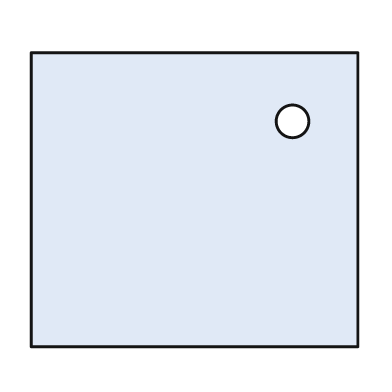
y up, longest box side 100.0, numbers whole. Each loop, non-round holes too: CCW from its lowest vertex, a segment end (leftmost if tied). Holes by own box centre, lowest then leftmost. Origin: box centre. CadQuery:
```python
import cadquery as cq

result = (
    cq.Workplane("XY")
    .moveTo(-50.0, -45.0)
    .lineTo(50.0, -45.0)
    .lineTo(50.0, 45.0)
    .lineTo(-50.0, 45.0)
    .close()
    .moveTo(30.0, 24.0)
    .circle(5.0)
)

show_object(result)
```